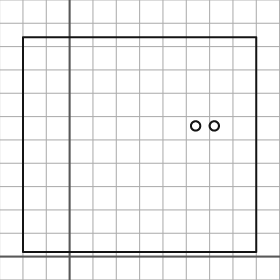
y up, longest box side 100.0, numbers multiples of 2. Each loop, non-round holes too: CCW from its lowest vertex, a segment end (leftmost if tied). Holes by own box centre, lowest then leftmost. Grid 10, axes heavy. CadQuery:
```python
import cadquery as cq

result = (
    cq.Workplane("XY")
    .moveTo(-20.0, 2.0)
    .lineTo(80.0, 2.0)
    .lineTo(80.0, 94.0)
    .lineTo(-20.0, 94.0)
    .close()
    .moveTo(54.0, 56.0)
    .circle(2.0)
    .moveTo(62.0, 56.0)
    .circle(2.0)
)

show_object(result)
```